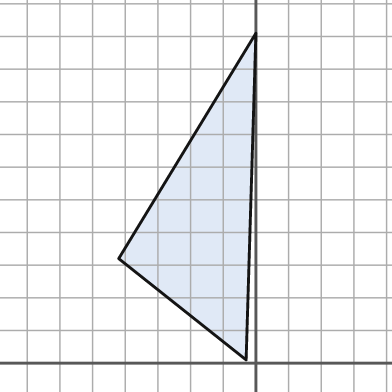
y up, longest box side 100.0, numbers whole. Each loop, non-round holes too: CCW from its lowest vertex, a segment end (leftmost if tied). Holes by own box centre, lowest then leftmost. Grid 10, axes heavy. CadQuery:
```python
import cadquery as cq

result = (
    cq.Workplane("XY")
    .moveTo(-3.0, 1.0)
    .lineTo(0.0, 101.0)
    .lineTo(-42.0, 32.0)
    .close()
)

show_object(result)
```